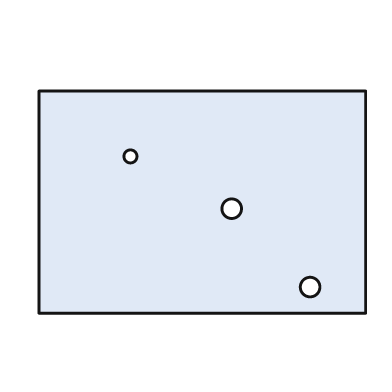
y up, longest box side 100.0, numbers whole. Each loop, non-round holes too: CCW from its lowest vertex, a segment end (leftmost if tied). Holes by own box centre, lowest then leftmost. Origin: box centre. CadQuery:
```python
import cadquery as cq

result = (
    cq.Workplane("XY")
    .moveTo(-50.0, -34.0)
    .lineTo(50.0, -34.0)
    .lineTo(50.0, 34.0)
    .lineTo(-50.0, 34.0)
    .close()
    .moveTo(33.0, -26.0)
    .circle(3.0)
    .moveTo(9.0, -2.0)
    .circle(3.0)
    .moveTo(-22.0, 14.0)
    .circle(2.0)
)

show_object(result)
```